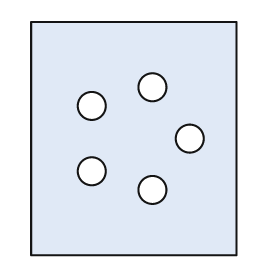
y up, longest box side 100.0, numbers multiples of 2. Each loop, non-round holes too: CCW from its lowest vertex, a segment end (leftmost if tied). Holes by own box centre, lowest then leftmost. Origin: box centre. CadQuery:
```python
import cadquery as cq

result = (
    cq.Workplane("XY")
    .moveTo(-44.0, -50.0)
    .lineTo(44.0, -50.0)
    .lineTo(44.0, 50.0)
    .lineTo(-44.0, 50.0)
    .close()
    .moveTo(8.0, -22.0)
    .circle(6.0)
    .moveTo(-18.0, -14.0)
    .circle(6.0)
    .moveTo(24.0, 0.0)
    .circle(6.0)
    .moveTo(-18.0, 14.0)
    .circle(6.0)
    .moveTo(8.0, 22.0)
    .circle(6.0)
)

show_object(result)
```